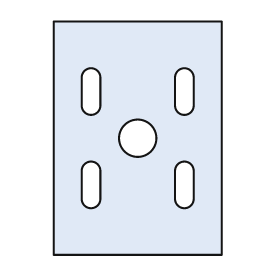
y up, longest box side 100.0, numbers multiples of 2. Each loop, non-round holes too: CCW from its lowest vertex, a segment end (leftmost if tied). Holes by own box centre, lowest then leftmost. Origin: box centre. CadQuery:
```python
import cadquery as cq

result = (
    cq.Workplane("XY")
    .moveTo(-36.0, -50.0)
    .lineTo(36.0, -50.0)
    .lineTo(36.0, 50.0)
    .lineTo(-36.0, 50.0)
    .close()
    .moveTo(-24.0, -26.0)
    .threePointArc((-20.0, -30.0), (-16.0, -26.0))
    .lineTo(-16.0, -14.0)
    .threePointArc((-20.0, -10.0), (-24.0, -14.0))
    .close()
    .moveTo(16.0, -26.0)
    .threePointArc((20.0, -30.0), (24.0, -26.0))
    .lineTo(24.0, -14.0)
    .threePointArc((20.0, -10.0), (16.0, -14.0))
    .close()
    .moveTo(0.0, 0.0)
    .circle(8.0)
    .moveTo(-24.0, 14.0)
    .threePointArc((-20.0, 10.0), (-16.0, 14.0))
    .lineTo(-16.0, 26.0)
    .threePointArc((-20.0, 30.0), (-24.0, 26.0))
    .close()
    .moveTo(16.0, 14.0)
    .threePointArc((20.0, 10.0), (24.0, 14.0))
    .lineTo(24.0, 26.0)
    .threePointArc((20.0, 30.0), (16.0, 26.0))
    .close()
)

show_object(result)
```